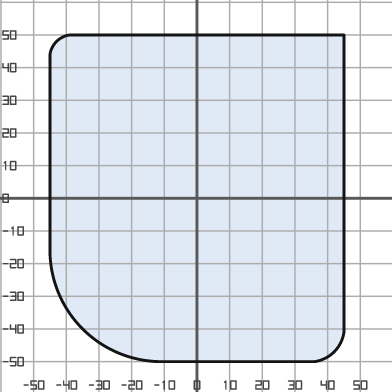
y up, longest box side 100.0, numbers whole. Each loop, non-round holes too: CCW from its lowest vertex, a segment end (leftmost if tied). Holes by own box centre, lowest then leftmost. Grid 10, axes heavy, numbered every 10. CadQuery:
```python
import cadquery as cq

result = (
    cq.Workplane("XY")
    .moveTo(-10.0, -50.0)
    .lineTo(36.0, -50.0)
    .threePointArc((42.0, -47.0), (45.0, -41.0))
    .lineTo(45.0, 50.0)
    .lineTo(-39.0, 50.0)
    .threePointArc((-43.0, 48.0), (-45.0, 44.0))
    .lineTo(-45.0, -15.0)
    .threePointArc((-35.0, -40.0), (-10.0, -50.0))
    .close()
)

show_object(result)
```